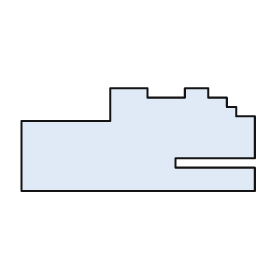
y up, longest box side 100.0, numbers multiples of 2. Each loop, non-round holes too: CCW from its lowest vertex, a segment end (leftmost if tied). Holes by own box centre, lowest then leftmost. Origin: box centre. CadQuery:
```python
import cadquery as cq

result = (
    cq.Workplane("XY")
    .moveTo(-50.0, -22.0)
    .lineTo(50.0, -22.0)
    .lineTo(50.0, -12.0)
    .lineTo(16.0, -12.0)
    .lineTo(16.0, -8.0)
    .lineTo(50.0, -8.0)
    .lineTo(50.0, 10.0)
    .lineTo(42.0, 10.0)
    .lineTo(42.0, 14.0)
    .lineTo(38.0, 14.0)
    .lineTo(38.0, 18.0)
    .lineTo(30.0, 18.0)
    .lineTo(30.0, 22.0)
    .lineTo(20.0, 22.0)
    .lineTo(20.0, 18.0)
    .lineTo(4.0, 18.0)
    .lineTo(4.0, 22.0)
    .lineTo(-12.0, 22.0)
    .lineTo(-12.0, 8.0)
    .lineTo(-50.0, 8.0)
    .close()
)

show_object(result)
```